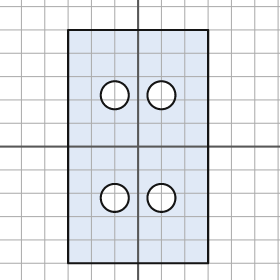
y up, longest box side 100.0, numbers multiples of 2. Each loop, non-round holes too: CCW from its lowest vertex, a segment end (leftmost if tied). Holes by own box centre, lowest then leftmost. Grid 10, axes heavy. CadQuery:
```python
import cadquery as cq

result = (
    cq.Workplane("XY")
    .moveTo(-30.0, -50.0)
    .lineTo(30.0, -50.0)
    .lineTo(30.0, 50.0)
    .lineTo(-30.0, 50.0)
    .close()
    .moveTo(-10.0, -22.0)
    .circle(6.0)
    .moveTo(10.0, -22.0)
    .circle(6.0)
    .moveTo(-10.0, 22.0)
    .circle(6.0)
    .moveTo(10.0, 22.0)
    .circle(6.0)
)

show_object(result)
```